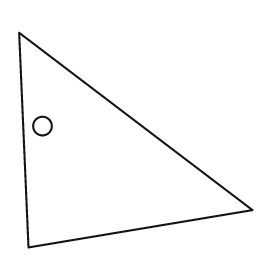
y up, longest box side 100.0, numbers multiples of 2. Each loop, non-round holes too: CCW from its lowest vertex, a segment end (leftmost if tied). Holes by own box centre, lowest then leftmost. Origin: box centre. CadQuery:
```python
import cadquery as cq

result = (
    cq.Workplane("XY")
    .moveTo(-46.0, -46.0)
    .lineTo(50.0, -30.0)
    .lineTo(-50.0, 46.0)
    .close()
    .moveTo(-40.0, 6.0)
    .circle(4.0)
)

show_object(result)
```